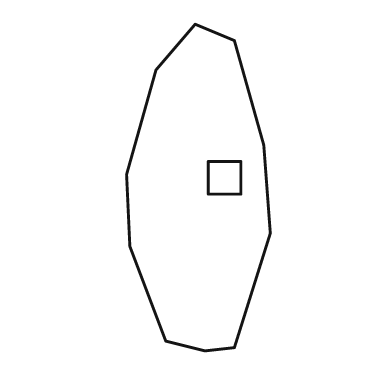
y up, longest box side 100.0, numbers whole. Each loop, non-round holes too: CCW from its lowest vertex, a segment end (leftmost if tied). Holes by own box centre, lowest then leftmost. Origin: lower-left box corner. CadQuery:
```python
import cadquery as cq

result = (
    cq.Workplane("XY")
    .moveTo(24.0, 0.0)
    .lineTo(33.0, 1.0)
    .lineTo(44.0, 36.0)
    .lineTo(42.0, 63.0)
    .lineTo(33.0, 95.0)
    .lineTo(21.0, 100.0)
    .lineTo(9.0, 86.0)
    .lineTo(0.0, 54.0)
    .lineTo(1.0, 32.0)
    .lineTo(12.0, 3.0)
    .close()
    .moveTo(25.0, 48.0)
    .lineTo(35.0, 48.0)
    .lineTo(35.0, 58.0)
    .lineTo(25.0, 58.0)
    .close()
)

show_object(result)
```